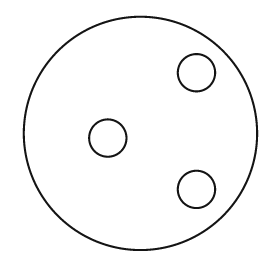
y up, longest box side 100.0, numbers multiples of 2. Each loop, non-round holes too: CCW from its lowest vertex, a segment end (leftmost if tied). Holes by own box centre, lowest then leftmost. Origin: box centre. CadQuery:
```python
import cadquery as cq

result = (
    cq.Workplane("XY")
    .moveTo(0.0, 0.0)
    .circle(50.0)
    .moveTo(24.0, -24.0)
    .circle(8.0)
    .moveTo(-14.0, -2.0)
    .circle(8.0)
    .moveTo(24.0, 26.0)
    .circle(8.0)
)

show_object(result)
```